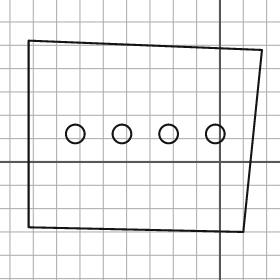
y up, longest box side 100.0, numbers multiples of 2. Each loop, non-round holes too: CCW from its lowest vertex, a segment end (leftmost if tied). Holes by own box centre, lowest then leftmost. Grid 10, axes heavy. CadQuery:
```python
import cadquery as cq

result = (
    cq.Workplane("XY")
    .moveTo(10.0, -30.0)
    .lineTo(18.0, 48.0)
    .lineTo(-82.0, 52.0)
    .lineTo(-82.0, -28.0)
    .close()
    .moveTo(-62.0, 12.0)
    .circle(4.0)
    .moveTo(-42.0, 12.0)
    .circle(4.0)
    .moveTo(-22.0, 12.0)
    .circle(4.0)
    .moveTo(-2.0, 12.0)
    .circle(4.0)
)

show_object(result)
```